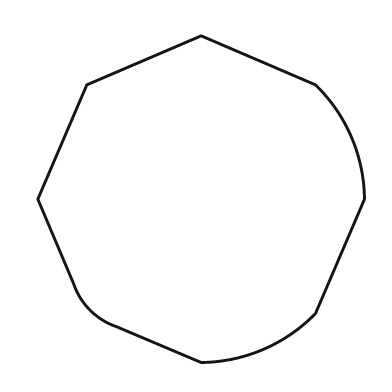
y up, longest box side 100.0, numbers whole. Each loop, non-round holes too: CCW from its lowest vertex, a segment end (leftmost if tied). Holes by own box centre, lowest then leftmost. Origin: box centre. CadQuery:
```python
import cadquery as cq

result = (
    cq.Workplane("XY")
    .moveTo(0.0, -50.0)
    .threePointArc((19.0, -46.0), (35.0, -35.0))
    .lineTo(50.0, 0.0)
    .threePointArc((46.0, 19.0), (35.0, 35.0))
    .lineTo(0.0, 50.0)
    .lineTo(-35.0, 35.0)
    .lineTo(-50.0, 0.0)
    .lineTo(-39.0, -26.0)
    .threePointArc((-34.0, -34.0), (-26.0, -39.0))
    .close()
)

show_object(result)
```